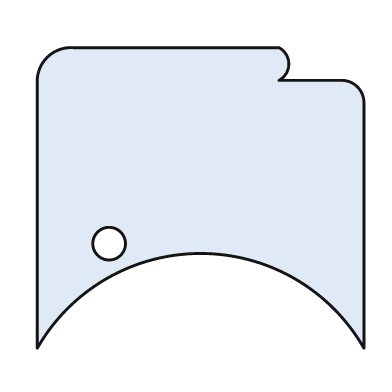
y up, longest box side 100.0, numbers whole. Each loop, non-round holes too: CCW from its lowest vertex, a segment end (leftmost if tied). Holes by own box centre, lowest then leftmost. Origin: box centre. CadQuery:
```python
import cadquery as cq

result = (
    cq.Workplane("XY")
    .moveTo(-50.0, -46.0)
    .threePointArc((0.0, -17.0), (50.0, -46.0))
    .lineTo(50.0, 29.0)
    .threePointArc((48.0, 34.0), (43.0, 36.0))
    .lineTo(24.0, 36.0)
    .threePointArc((27.0, 41.0), (24.0, 46.0))
    .lineTo(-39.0, 46.0)
    .threePointArc((-47.0, 43.0), (-50.0, 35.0))
    .close()
    .moveTo(-28.0, -14.0)
    .circle(5.0)
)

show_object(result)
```